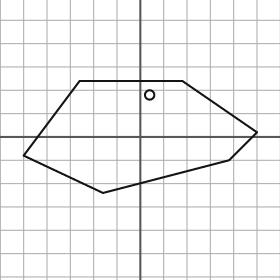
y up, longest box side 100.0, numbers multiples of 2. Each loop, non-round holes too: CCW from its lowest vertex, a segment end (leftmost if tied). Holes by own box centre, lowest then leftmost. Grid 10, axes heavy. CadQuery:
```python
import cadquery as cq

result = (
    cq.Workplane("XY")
    .moveTo(-16.0, -24.0)
    .lineTo(38.0, -10.0)
    .lineTo(50.0, 2.0)
    .lineTo(18.0, 24.0)
    .lineTo(-26.0, 24.0)
    .lineTo(-50.0, -8.0)
    .close()
    .moveTo(4.0, 18.0)
    .circle(2.0)
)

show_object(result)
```